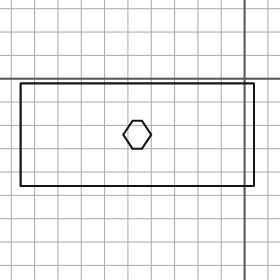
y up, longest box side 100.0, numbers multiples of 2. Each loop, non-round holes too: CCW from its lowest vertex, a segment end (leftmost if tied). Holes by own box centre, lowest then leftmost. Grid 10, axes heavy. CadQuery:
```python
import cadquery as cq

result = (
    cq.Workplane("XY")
    .moveTo(-96.0, -46.0)
    .lineTo(4.0, -46.0)
    .lineTo(4.0, -2.0)
    .lineTo(-96.0, -2.0)
    .close()
    .moveTo(-48.0, -30.0)
    .lineTo(-44.0, -30.0)
    .lineTo(-40.0, -24.0)
    .lineTo(-44.0, -18.0)
    .lineTo(-48.0, -18.0)
    .lineTo(-52.0, -24.0)
    .close()
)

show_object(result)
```